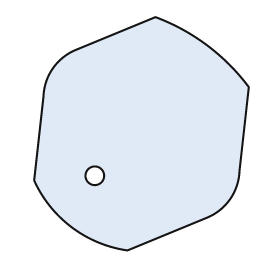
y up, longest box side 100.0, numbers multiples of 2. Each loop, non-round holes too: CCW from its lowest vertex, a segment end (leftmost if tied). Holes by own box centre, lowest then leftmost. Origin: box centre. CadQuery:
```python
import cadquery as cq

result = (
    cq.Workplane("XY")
    .moveTo(-6.0, -50.0)
    .lineTo(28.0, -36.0)
    .threePointArc((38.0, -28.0), (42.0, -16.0))
    .lineTo(46.0, 20.0)
    .threePointArc((28.0, 38.0), (6.0, 50.0))
    .lineTo(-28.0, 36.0)
    .threePointArc((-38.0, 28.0), (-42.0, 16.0))
    .lineTo(-46.0, -20.0)
    .threePointArc((-30.0, -40.0), (-6.0, -50.0))
    .close()
    .moveTo(-20.0, -18.0)
    .circle(4.0)
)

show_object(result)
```